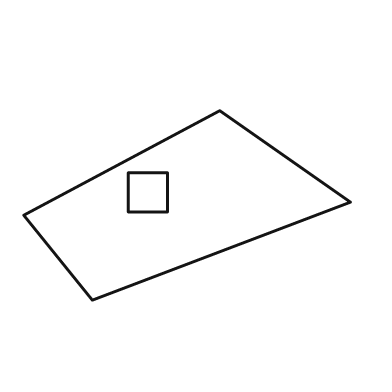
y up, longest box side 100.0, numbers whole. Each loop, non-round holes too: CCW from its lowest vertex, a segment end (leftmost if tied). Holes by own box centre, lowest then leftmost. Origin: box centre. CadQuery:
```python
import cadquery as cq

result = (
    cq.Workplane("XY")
    .moveTo(-29.0, -29.0)
    .lineTo(50.0, 1.0)
    .lineTo(10.0, 29.0)
    .lineTo(-50.0, -3.0)
    .close()
    .moveTo(-18.0, -2.0)
    .lineTo(-6.0, -2.0)
    .lineTo(-6.0, 10.0)
    .lineTo(-18.0, 10.0)
    .close()
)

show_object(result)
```